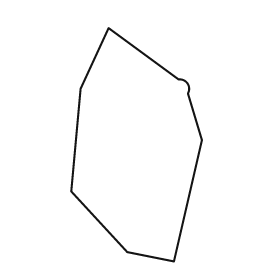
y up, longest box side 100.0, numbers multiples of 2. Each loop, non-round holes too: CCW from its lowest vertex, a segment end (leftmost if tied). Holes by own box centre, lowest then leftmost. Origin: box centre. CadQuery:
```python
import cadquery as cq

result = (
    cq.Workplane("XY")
    .moveTo(16.0, -50.0)
    .lineTo(28.0, 2.0)
    .lineTo(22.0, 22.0)
    .threePointArc((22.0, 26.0), (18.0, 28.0))
    .lineTo(-12.0, 50.0)
    .lineTo(-24.0, 24.0)
    .lineTo(-28.0, -20.0)
    .lineTo(-4.0, -46.0)
    .close()
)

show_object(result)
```